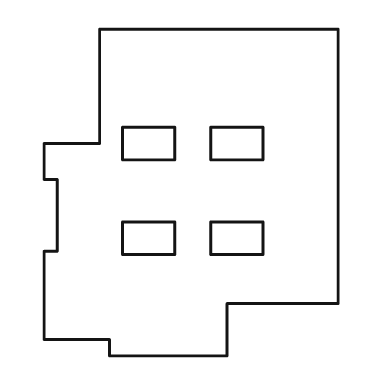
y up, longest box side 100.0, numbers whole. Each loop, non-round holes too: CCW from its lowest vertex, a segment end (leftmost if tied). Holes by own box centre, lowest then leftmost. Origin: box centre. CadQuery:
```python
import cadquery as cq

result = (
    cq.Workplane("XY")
    .moveTo(-25.0, -50.0)
    .lineTo(11.0, -50.0)
    .lineTo(11.0, -34.0)
    .lineTo(45.0, -34.0)
    .lineTo(45.0, 50.0)
    .lineTo(-28.0, 50.0)
    .lineTo(-28.0, 15.0)
    .lineTo(-45.0, 15.0)
    .lineTo(-45.0, 4.0)
    .lineTo(-41.0, 4.0)
    .lineTo(-41.0, -18.0)
    .lineTo(-45.0, -18.0)
    .lineTo(-45.0, -45.0)
    .lineTo(-25.0, -45.0)
    .close()
    .moveTo(-21.0, -19.0)
    .lineTo(-5.0, -19.0)
    .lineTo(-5.0, -9.0)
    .lineTo(-21.0, -9.0)
    .close()
    .moveTo(6.0, -19.0)
    .lineTo(22.0, -19.0)
    .lineTo(22.0, -9.0)
    .lineTo(6.0, -9.0)
    .close()
    .moveTo(-21.0, 10.0)
    .lineTo(-5.0, 10.0)
    .lineTo(-5.0, 20.0)
    .lineTo(-21.0, 20.0)
    .close()
    .moveTo(6.0, 10.0)
    .lineTo(22.0, 10.0)
    .lineTo(22.0, 20.0)
    .lineTo(6.0, 20.0)
    .close()
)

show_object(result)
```